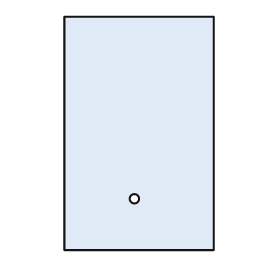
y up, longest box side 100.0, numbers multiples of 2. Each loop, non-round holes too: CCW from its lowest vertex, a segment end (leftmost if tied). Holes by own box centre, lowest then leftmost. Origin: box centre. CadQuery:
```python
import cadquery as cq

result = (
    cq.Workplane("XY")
    .moveTo(-32.0, -50.0)
    .lineTo(32.0, -50.0)
    .lineTo(32.0, 50.0)
    .lineTo(-32.0, 50.0)
    .close()
    .moveTo(-2.0, -28.0)
    .circle(2.0)
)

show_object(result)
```